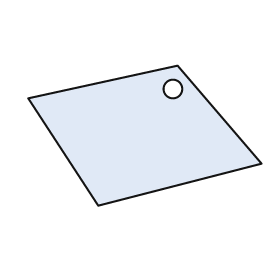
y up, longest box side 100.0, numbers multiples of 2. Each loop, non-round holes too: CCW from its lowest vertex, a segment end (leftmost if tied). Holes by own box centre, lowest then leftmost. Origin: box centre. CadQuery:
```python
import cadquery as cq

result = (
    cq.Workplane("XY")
    .moveTo(-20.0, -30.0)
    .lineTo(50.0, -12.0)
    .lineTo(14.0, 30.0)
    .lineTo(-50.0, 16.0)
    .close()
    .moveTo(12.0, 20.0)
    .circle(4.0)
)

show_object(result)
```